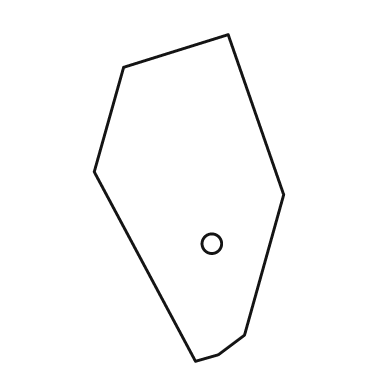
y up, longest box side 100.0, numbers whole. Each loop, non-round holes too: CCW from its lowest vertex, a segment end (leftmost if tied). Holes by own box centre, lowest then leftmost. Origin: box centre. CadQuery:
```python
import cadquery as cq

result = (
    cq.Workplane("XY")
    .moveTo(2.0, -50.0)
    .lineTo(9.0, -48.0)
    .lineTo(17.0, -42.0)
    .lineTo(29.0, 1.0)
    .lineTo(12.0, 50.0)
    .lineTo(-20.0, 40.0)
    .lineTo(-29.0, 8.0)
    .close()
    .moveTo(7.0, -14.0)
    .circle(3.0)
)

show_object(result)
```